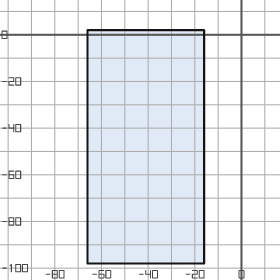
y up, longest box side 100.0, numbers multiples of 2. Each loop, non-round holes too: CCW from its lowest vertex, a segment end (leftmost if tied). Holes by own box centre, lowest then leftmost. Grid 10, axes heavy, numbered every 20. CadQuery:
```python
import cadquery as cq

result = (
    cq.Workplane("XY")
    .moveTo(-66.0, -98.0)
    .lineTo(-16.0, -98.0)
    .lineTo(-16.0, 2.0)
    .lineTo(-66.0, 2.0)
    .close()
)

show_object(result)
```